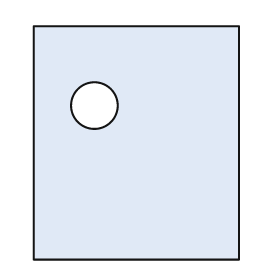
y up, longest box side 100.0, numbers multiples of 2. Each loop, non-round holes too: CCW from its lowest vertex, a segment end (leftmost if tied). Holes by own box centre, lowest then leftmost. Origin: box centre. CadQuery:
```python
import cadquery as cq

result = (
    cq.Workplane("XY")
    .moveTo(-44.0, -50.0)
    .lineTo(44.0, -50.0)
    .lineTo(44.0, 50.0)
    .lineTo(-44.0, 50.0)
    .close()
    .moveTo(-18.0, 16.0)
    .circle(10.0)
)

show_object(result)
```